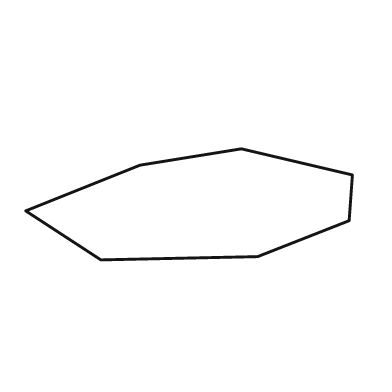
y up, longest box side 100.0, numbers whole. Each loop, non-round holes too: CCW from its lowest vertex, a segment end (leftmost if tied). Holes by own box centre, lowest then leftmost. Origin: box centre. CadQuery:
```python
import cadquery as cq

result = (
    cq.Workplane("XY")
    .moveTo(-27.0, -17.0)
    .lineTo(21.0, -16.0)
    .lineTo(49.0, -5.0)
    .lineTo(50.0, 9.0)
    .lineTo(16.0, 17.0)
    .lineTo(-15.0, 12.0)
    .lineTo(-50.0, -2.0)
    .close()
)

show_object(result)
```